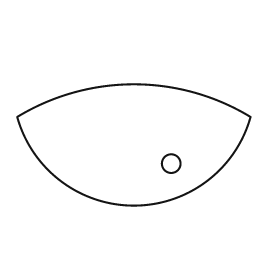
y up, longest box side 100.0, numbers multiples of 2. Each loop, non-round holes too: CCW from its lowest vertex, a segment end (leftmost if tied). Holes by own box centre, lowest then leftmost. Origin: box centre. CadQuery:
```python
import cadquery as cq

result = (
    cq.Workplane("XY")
    .moveTo(-50.0, 12.0)
    .threePointArc((0.0, -26.0), (50.0, 12.0))
    .threePointArc((0.0, 26.0), (-50.0, 12.0))
    .close()
    .moveTo(16.0, -8.0)
    .circle(4.0)
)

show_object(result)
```